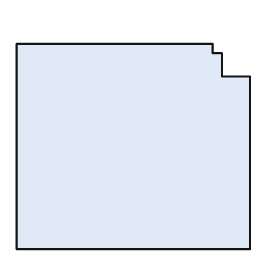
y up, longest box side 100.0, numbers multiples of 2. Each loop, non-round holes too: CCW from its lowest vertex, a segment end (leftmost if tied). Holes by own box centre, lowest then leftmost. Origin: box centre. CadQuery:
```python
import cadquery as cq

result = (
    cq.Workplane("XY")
    .moveTo(-50.0, -44.0)
    .lineTo(50.0, -44.0)
    .lineTo(50.0, 30.0)
    .lineTo(38.0, 30.0)
    .lineTo(38.0, 40.0)
    .lineTo(34.0, 40.0)
    .lineTo(34.0, 44.0)
    .lineTo(-50.0, 44.0)
    .close()
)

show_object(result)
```